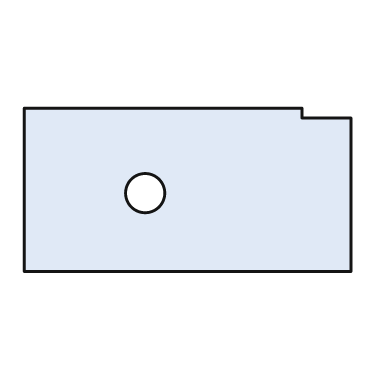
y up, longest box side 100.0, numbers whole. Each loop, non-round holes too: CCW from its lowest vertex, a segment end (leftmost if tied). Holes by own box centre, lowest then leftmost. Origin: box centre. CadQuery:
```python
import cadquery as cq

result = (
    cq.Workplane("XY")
    .moveTo(-50.0, -25.0)
    .lineTo(50.0, -25.0)
    .lineTo(50.0, 22.0)
    .lineTo(35.0, 22.0)
    .lineTo(35.0, 25.0)
    .lineTo(-50.0, 25.0)
    .close()
    .moveTo(-13.0, -1.0)
    .circle(6.0)
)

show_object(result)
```